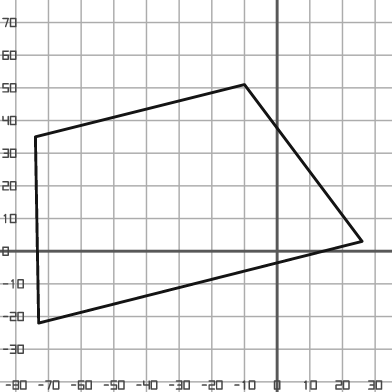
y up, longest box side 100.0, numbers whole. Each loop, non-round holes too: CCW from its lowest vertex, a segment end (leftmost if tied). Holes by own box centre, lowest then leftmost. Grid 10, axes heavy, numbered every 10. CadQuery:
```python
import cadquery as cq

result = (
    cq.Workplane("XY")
    .moveTo(-73.0, -22.0)
    .lineTo(26.0, 3.0)
    .lineTo(-10.0, 51.0)
    .lineTo(-74.0, 35.0)
    .close()
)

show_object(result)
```